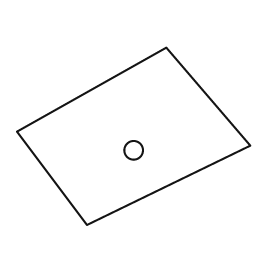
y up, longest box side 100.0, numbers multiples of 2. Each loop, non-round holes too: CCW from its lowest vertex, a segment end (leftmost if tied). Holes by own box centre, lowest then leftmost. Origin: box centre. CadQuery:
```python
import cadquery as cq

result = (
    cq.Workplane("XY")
    .moveTo(-20.0, -38.0)
    .lineTo(50.0, -4.0)
    .lineTo(14.0, 38.0)
    .lineTo(-50.0, 2.0)
    .close()
    .moveTo(0.0, -6.0)
    .circle(4.0)
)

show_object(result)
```